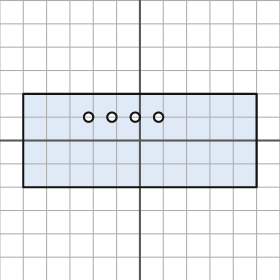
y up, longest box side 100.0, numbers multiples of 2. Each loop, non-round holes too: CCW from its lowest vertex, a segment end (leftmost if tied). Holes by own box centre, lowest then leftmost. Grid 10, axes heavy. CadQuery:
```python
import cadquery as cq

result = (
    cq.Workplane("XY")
    .moveTo(-50.0, -20.0)
    .lineTo(50.0, -20.0)
    .lineTo(50.0, 20.0)
    .lineTo(-50.0, 20.0)
    .close()
    .moveTo(-22.0, 10.0)
    .circle(2.0)
    .moveTo(-12.0, 10.0)
    .circle(2.0)
    .moveTo(-2.0, 10.0)
    .circle(2.0)
    .moveTo(8.0, 10.0)
    .circle(2.0)
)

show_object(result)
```